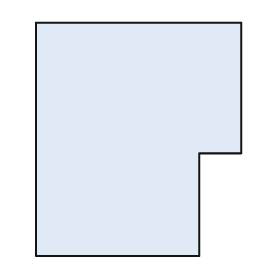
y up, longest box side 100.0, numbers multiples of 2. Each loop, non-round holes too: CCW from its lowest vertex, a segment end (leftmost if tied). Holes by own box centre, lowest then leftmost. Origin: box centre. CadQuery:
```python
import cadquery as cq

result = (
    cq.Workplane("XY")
    .moveTo(-44.0, -50.0)
    .lineTo(26.0, -50.0)
    .lineTo(26.0, -6.0)
    .lineTo(44.0, -6.0)
    .lineTo(44.0, 50.0)
    .lineTo(-44.0, 50.0)
    .close()
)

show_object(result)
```